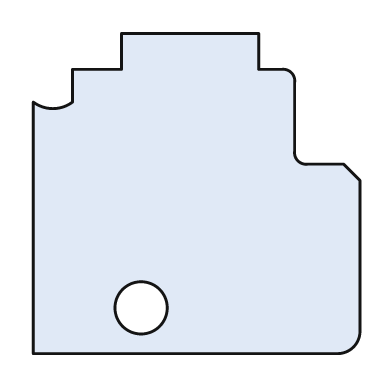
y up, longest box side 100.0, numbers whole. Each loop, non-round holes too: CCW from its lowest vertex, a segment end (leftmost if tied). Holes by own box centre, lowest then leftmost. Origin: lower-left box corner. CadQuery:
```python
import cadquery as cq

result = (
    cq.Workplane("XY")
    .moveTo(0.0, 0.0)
    .lineTo(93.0, 0.0)
    .threePointArc((98.0, 2.0), (100.0, 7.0))
    .lineTo(100.0, 53.0)
    .lineTo(95.0, 58.0)
    .lineTo(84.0, 58.0)
    .threePointArc((81.0, 59.0), (80.0, 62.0))
    .lineTo(80.0, 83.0)
    .threePointArc((79.0, 86.0), (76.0, 87.0))
    .lineTo(69.0, 87.0)
    .lineTo(69.0, 98.0)
    .lineTo(27.0, 98.0)
    .lineTo(27.0, 87.0)
    .lineTo(12.0, 87.0)
    .lineTo(12.0, 77.0)
    .threePointArc((6.0, 75.0), (0.0, 77.0))
    .close()
    .moveTo(33.0, 14.0)
    .circle(8.0)
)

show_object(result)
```